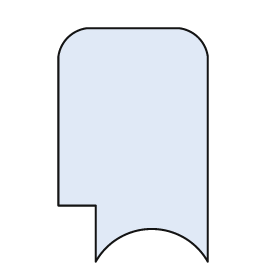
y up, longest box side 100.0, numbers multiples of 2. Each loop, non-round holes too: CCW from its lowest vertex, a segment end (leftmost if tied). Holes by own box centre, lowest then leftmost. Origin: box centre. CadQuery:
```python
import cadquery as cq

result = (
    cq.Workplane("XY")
    .moveTo(-16.0, -50.0)
    .threePointArc((8.0, -36.0), (32.0, -50.0))
    .lineTo(32.0, 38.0)
    .threePointArc((28.0, 46.0), (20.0, 50.0))
    .lineTo(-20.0, 50.0)
    .threePointArc((-28.0, 46.0), (-32.0, 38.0))
    .lineTo(-32.0, -26.0)
    .lineTo(-16.0, -26.0)
    .close()
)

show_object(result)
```